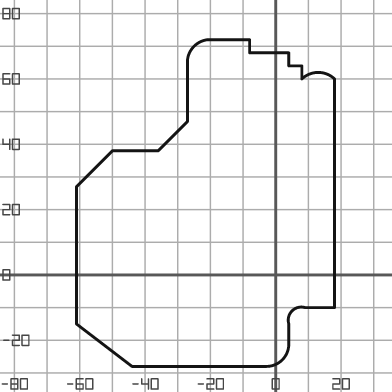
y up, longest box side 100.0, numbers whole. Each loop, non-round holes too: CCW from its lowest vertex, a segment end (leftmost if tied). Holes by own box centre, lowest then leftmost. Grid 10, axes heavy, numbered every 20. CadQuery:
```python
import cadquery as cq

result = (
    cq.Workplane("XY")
    .moveTo(-44.0, -28.0)
    .lineTo(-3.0, -28.0)
    .threePointArc((2.0, -26.0), (4.0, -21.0))
    .lineTo(4.0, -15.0)
    .threePointArc((5.0, -11.0), (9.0, -10.0))
    .lineTo(18.0, -10.0)
    .lineTo(18.0, 60.0)
    .threePointArc((13.0, 62.0), (8.0, 60.0))
    .lineTo(8.0, 64.0)
    .lineTo(4.0, 64.0)
    .lineTo(4.0, 68.0)
    .lineTo(-8.0, 68.0)
    .lineTo(-8.0, 72.0)
    .lineTo(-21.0, 72.0)
    .threePointArc((-25.0, 70.0), (-27.0, 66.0))
    .lineTo(-27.0, 47.0)
    .lineTo(-36.0, 38.0)
    .lineTo(-50.0, 38.0)
    .lineTo(-61.0, 27.0)
    .lineTo(-61.0, -15.0)
    .close()
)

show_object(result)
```